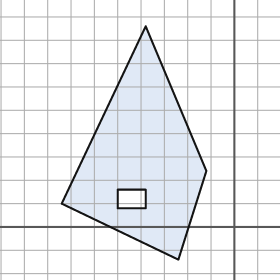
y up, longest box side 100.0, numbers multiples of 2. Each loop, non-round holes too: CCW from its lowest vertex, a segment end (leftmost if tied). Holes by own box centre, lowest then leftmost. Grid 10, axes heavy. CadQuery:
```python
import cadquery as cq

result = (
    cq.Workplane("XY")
    .moveTo(-24.0, -14.0)
    .lineTo(-12.0, 24.0)
    .lineTo(-38.0, 86.0)
    .lineTo(-74.0, 10.0)
    .close()
    .moveTo(-50.0, 8.0)
    .lineTo(-38.0, 8.0)
    .lineTo(-38.0, 16.0)
    .lineTo(-50.0, 16.0)
    .close()
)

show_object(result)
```